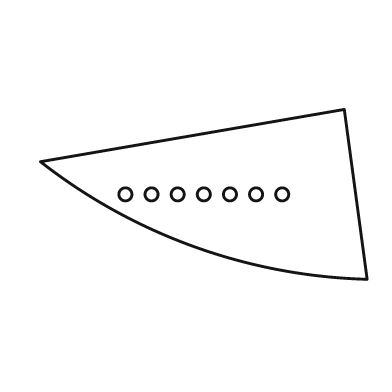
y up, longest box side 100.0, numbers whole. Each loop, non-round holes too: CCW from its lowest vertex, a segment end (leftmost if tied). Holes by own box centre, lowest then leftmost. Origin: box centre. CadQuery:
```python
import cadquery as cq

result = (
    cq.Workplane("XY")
    .moveTo(50.0, -26.0)
    .lineTo(43.0, 26.0)
    .lineTo(-50.0, 10.0)
    .threePointArc((-3.0, -16.0), (50.0, -26.0))
    .close()
    .moveTo(-24.0, 0.0)
    .circle(2.0)
    .moveTo(-16.0, 0.0)
    .circle(2.0)
    .moveTo(-8.0, 0.0)
    .circle(2.0)
    .moveTo(0.0, 0.0)
    .circle(2.0)
    .moveTo(8.0, 0.0)
    .circle(2.0)
    .moveTo(16.0, 0.0)
    .circle(2.0)
    .moveTo(24.0, 0.0)
    .circle(2.0)
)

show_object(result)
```